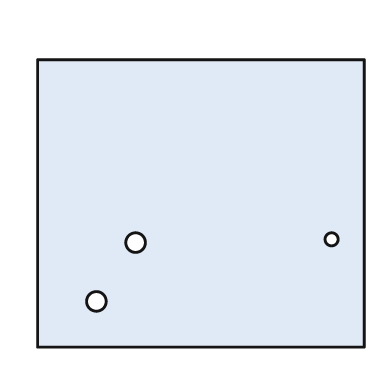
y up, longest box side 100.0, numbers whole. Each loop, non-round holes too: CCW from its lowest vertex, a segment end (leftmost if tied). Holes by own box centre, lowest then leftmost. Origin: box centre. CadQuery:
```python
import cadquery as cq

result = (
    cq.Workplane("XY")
    .moveTo(-50.0, -44.0)
    .lineTo(50.0, -44.0)
    .lineTo(50.0, 44.0)
    .lineTo(-50.0, 44.0)
    .close()
    .moveTo(-32.0, -30.0)
    .circle(3.0)
    .moveTo(-20.0, -12.0)
    .circle(3.0)
    .moveTo(40.0, -11.0)
    .circle(2.0)
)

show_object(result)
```